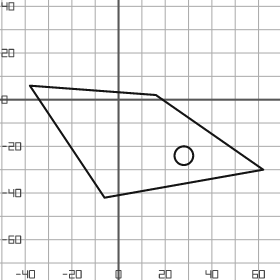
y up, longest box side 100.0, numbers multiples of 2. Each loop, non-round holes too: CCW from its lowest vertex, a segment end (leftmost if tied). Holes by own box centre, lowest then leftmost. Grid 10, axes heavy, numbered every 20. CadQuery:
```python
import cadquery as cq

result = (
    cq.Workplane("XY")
    .moveTo(-6.0, -42.0)
    .lineTo(62.0, -30.0)
    .lineTo(16.0, 2.0)
    .lineTo(-38.0, 6.0)
    .close()
    .moveTo(28.0, -24.0)
    .circle(4.0)
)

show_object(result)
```